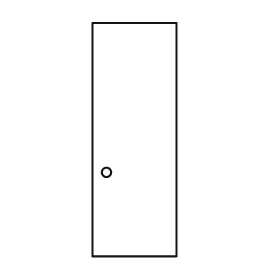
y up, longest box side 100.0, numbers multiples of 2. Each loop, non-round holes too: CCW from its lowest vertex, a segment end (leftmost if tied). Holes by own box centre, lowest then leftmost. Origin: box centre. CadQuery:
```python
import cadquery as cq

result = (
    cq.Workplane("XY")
    .moveTo(-18.0, -50.0)
    .lineTo(18.0, -50.0)
    .lineTo(18.0, 50.0)
    .lineTo(-18.0, 50.0)
    .close()
    .moveTo(-12.0, -14.0)
    .circle(2.0)
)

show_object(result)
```